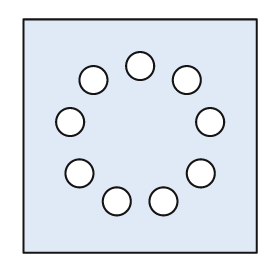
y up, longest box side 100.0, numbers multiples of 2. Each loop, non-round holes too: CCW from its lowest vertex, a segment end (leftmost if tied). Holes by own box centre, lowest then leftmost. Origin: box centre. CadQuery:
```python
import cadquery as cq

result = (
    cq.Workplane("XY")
    .moveTo(-50.0, -50.0)
    .lineTo(50.0, -50.0)
    .lineTo(50.0, 50.0)
    .lineTo(-50.0, 50.0)
    .close()
    .moveTo(-10.0, -28.0)
    .circle(6.0)
    .moveTo(10.0, -28.0)
    .circle(6.0)
    .moveTo(-26.0, -16.0)
    .circle(6.0)
    .moveTo(26.0, -16.0)
    .circle(6.0)
    .moveTo(-30.0, 6.0)
    .circle(6.0)
    .moveTo(30.0, 6.0)
    .circle(6.0)
    .moveTo(-20.0, 24.0)
    .circle(6.0)
    .moveTo(20.0, 24.0)
    .circle(6.0)
    .moveTo(0.0, 30.0)
    .circle(6.0)
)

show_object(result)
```